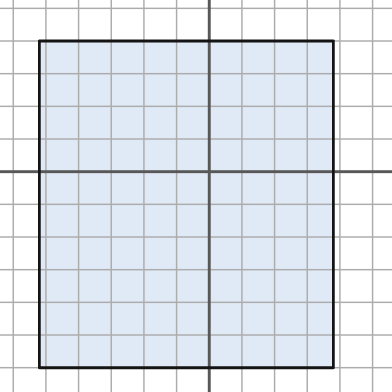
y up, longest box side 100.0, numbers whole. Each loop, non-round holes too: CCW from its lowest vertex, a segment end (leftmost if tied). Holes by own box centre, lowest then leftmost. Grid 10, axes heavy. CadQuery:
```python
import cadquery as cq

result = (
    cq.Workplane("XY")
    .moveTo(-52.0, -60.0)
    .lineTo(38.0, -60.0)
    .lineTo(38.0, 40.0)
    .lineTo(-52.0, 40.0)
    .close()
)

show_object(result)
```